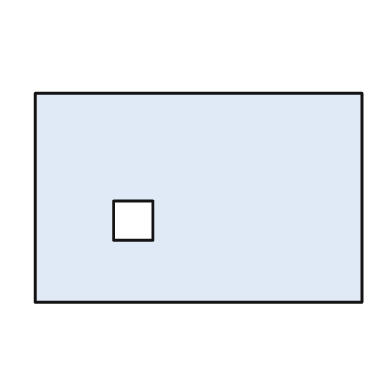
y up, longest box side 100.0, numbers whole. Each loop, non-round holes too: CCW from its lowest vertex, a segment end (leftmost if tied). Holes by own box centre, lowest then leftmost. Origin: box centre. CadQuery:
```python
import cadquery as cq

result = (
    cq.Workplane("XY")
    .moveTo(-50.0, -32.0)
    .lineTo(50.0, -32.0)
    .lineTo(50.0, 32.0)
    .lineTo(-50.0, 32.0)
    .close()
    .moveTo(-26.0, -13.0)
    .lineTo(-14.0, -13.0)
    .lineTo(-14.0, -1.0)
    .lineTo(-26.0, -1.0)
    .close()
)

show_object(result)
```